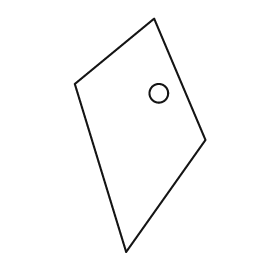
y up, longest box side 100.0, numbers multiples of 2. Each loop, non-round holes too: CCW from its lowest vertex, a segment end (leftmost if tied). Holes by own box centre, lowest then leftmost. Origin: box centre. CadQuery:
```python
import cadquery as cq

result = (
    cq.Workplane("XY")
    .moveTo(-6.0, -50.0)
    .lineTo(28.0, -2.0)
    .lineTo(6.0, 50.0)
    .lineTo(-28.0, 22.0)
    .close()
    .moveTo(8.0, 18.0)
    .circle(4.0)
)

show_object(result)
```